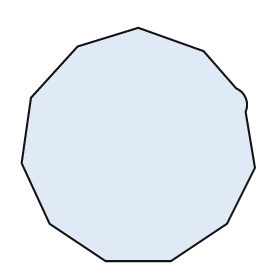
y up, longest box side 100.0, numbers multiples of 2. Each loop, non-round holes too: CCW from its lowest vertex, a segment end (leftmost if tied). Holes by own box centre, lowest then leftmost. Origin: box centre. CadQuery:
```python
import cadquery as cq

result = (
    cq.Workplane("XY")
    .moveTo(-14.0, -50.0)
    .lineTo(14.0, -50.0)
    .lineTo(38.0, -34.0)
    .lineTo(50.0, -10.0)
    .lineTo(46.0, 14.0)
    .threePointArc((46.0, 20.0), (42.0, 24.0))
    .lineTo(28.0, 40.0)
    .lineTo(0.0, 50.0)
    .lineTo(-26.0, 42.0)
    .lineTo(-46.0, 20.0)
    .lineTo(-50.0, -8.0)
    .lineTo(-38.0, -34.0)
    .close()
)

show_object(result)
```